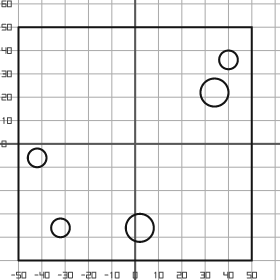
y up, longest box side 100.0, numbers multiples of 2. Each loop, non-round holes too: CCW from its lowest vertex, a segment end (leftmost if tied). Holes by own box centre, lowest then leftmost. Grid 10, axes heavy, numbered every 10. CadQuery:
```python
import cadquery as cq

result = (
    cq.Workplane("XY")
    .moveTo(-50.0, -50.0)
    .lineTo(50.0, -50.0)
    .lineTo(50.0, 50.0)
    .lineTo(-50.0, 50.0)
    .close()
    .moveTo(-32.0, -36.0)
    .circle(4.0)
    .moveTo(2.0, -36.0)
    .circle(6.0)
    .moveTo(-42.0, -6.0)
    .circle(4.0)
    .moveTo(34.0, 22.0)
    .circle(6.0)
    .moveTo(40.0, 36.0)
    .circle(4.0)
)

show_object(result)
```